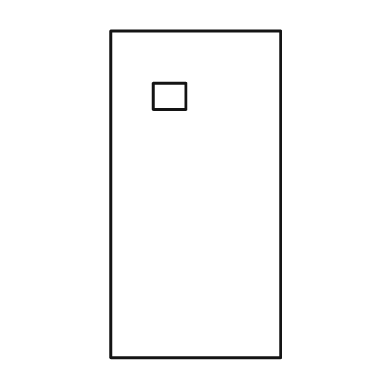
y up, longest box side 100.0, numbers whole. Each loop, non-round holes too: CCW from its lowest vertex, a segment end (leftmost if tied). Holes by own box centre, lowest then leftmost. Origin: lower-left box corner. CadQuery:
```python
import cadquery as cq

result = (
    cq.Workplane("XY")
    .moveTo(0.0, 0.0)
    .lineTo(52.0, 0.0)
    .lineTo(52.0, 100.0)
    .lineTo(0.0, 100.0)
    .close()
    .moveTo(13.0, 76.0)
    .lineTo(23.0, 76.0)
    .lineTo(23.0, 84.0)
    .lineTo(13.0, 84.0)
    .close()
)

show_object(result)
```